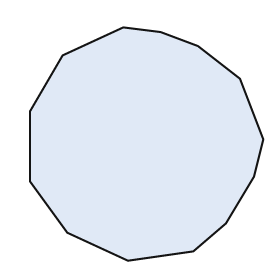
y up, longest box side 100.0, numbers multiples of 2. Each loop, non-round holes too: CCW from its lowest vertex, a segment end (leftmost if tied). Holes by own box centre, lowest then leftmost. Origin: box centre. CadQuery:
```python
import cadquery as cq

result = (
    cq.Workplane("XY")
    .moveTo(-8.0, -50.0)
    .lineTo(20.0, -46.0)
    .lineTo(34.0, -34.0)
    .lineTo(46.0, -14.0)
    .lineTo(50.0, 2.0)
    .lineTo(40.0, 28.0)
    .lineTo(22.0, 42.0)
    .lineTo(6.0, 48.0)
    .lineTo(-10.0, 50.0)
    .lineTo(-36.0, 38.0)
    .lineTo(-50.0, 14.0)
    .lineTo(-50.0, -16.0)
    .lineTo(-34.0, -38.0)
    .close()
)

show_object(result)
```